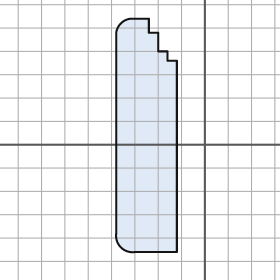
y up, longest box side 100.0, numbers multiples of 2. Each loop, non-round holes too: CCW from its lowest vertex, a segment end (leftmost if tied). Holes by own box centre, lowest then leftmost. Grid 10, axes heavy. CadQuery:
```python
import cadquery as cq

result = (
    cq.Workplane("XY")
    .moveTo(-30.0, -46.0)
    .lineTo(-12.0, -46.0)
    .lineTo(-12.0, 36.0)
    .lineTo(-16.0, 36.0)
    .lineTo(-16.0, 40.0)
    .lineTo(-20.0, 40.0)
    .lineTo(-20.0, 48.0)
    .lineTo(-24.0, 48.0)
    .lineTo(-24.0, 54.0)
    .lineTo(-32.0, 54.0)
    .threePointArc((-36.0, 52.0), (-38.0, 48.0))
    .lineTo(-38.0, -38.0)
    .threePointArc((-36.0, -44.0), (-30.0, -46.0))
    .close()
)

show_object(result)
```